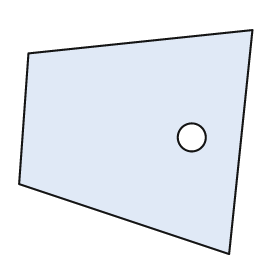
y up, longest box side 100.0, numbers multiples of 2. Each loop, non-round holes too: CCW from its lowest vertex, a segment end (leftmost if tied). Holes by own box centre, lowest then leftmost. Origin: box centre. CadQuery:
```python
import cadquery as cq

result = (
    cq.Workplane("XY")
    .moveTo(40.0, -48.0)
    .lineTo(50.0, 48.0)
    .lineTo(-46.0, 38.0)
    .lineTo(-50.0, -18.0)
    .close()
    .moveTo(24.0, 2.0)
    .circle(6.0)
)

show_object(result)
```